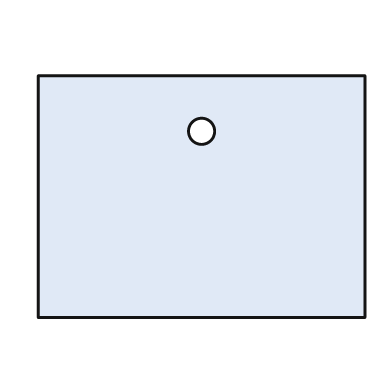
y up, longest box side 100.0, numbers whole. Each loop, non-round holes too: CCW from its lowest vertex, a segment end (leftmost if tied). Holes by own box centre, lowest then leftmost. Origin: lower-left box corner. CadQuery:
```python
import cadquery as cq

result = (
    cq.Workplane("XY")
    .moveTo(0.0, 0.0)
    .lineTo(100.0, 0.0)
    .lineTo(100.0, 74.0)
    .lineTo(0.0, 74.0)
    .close()
    .moveTo(50.0, 57.0)
    .circle(4.0)
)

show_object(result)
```